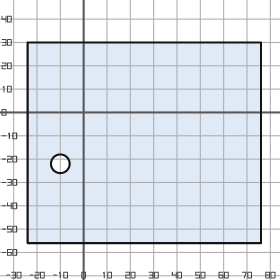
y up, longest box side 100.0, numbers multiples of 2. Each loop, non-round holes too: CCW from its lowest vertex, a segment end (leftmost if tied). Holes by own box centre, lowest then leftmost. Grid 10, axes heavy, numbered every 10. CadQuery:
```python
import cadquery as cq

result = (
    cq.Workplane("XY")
    .moveTo(-24.0, -56.0)
    .lineTo(76.0, -56.0)
    .lineTo(76.0, 30.0)
    .lineTo(-24.0, 30.0)
    .close()
    .moveTo(-10.0, -22.0)
    .circle(4.0)
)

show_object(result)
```